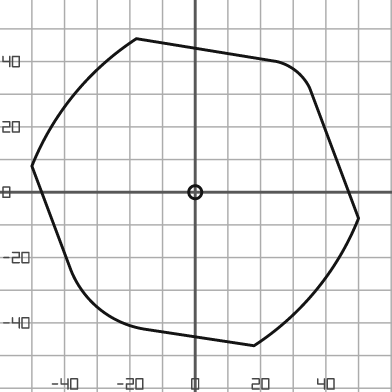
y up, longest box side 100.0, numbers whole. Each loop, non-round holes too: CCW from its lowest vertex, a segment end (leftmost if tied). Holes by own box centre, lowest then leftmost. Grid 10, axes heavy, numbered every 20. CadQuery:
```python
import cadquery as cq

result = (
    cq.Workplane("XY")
    .moveTo(18.0, -47.0)
    .threePointArc((37.0, -30.0), (50.0, -8.0))
    .lineTo(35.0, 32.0)
    .threePointArc((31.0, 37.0), (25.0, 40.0))
    .lineTo(-18.0, 47.0)
    .threePointArc((-37.0, 30.0), (-50.0, 8.0))
    .lineTo(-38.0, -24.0)
    .threePointArc((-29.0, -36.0), (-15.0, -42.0))
    .close()
    .moveTo(0.0, 0.0)
    .circle(2.0)
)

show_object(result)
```